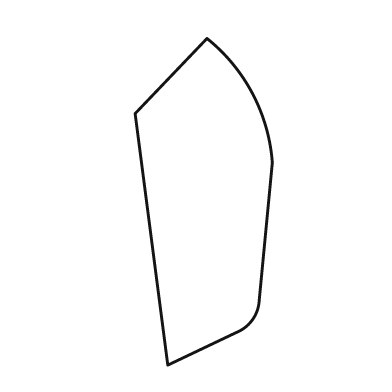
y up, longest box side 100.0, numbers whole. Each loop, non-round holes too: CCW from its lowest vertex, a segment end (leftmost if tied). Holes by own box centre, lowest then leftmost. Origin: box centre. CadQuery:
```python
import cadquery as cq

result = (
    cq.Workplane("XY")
    .moveTo(-11.0, -50.0)
    .lineTo(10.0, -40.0)
    .threePointArc((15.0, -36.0), (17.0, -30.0))
    .lineTo(21.0, 12.0)
    .threePointArc((15.0, 33.0), (1.0, 50.0))
    .lineTo(-21.0, 27.0)
    .close()
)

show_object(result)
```